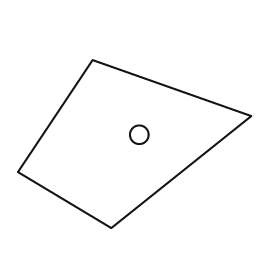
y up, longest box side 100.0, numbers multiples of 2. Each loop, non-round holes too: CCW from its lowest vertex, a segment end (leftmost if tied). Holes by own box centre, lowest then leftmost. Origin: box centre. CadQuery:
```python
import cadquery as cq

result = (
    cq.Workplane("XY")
    .moveTo(-10.0, -36.0)
    .lineTo(50.0, 12.0)
    .lineTo(-18.0, 36.0)
    .lineTo(-50.0, -12.0)
    .close()
    .moveTo(2.0, 4.0)
    .circle(4.0)
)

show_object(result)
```